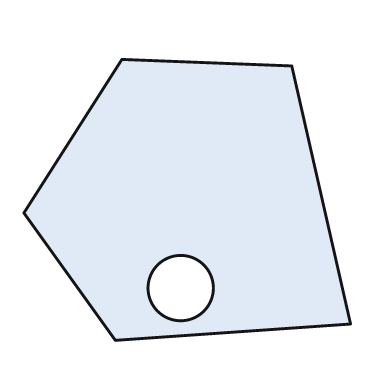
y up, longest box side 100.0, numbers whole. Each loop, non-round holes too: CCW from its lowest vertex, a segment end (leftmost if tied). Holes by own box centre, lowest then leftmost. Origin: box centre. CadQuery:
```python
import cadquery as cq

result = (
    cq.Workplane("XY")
    .moveTo(-22.0, -43.0)
    .lineTo(50.0, -38.0)
    .lineTo(32.0, 41.0)
    .lineTo(-20.0, 43.0)
    .lineTo(-50.0, -4.0)
    .close()
    .moveTo(-2.0, -27.0)
    .circle(10.0)
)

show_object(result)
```